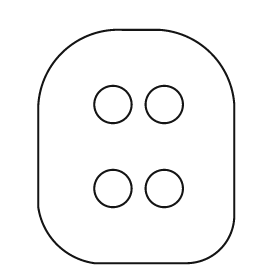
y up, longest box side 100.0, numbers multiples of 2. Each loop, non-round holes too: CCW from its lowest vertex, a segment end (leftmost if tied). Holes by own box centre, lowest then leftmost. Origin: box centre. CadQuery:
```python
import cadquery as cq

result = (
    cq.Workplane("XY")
    .moveTo(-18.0, -50.0)
    .lineTo(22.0, -50.0)
    .threePointArc((36.0, -44.0), (42.0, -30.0))
    .lineTo(42.0, 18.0)
    .threePointArc((32.0, 40.0), (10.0, 50.0))
    .lineTo(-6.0, 50.0)
    .threePointArc((-32.0, 40.0), (-42.0, 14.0))
    .lineTo(-42.0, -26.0)
    .threePointArc((-34.0, -42.0), (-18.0, -50.0))
    .close()
    .moveTo(-10.0, -18.0)
    .circle(8.0)
    .moveTo(12.0, -18.0)
    .circle(8.0)
    .moveTo(-10.0, 18.0)
    .circle(8.0)
    .moveTo(12.0, 18.0)
    .circle(8.0)
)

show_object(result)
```